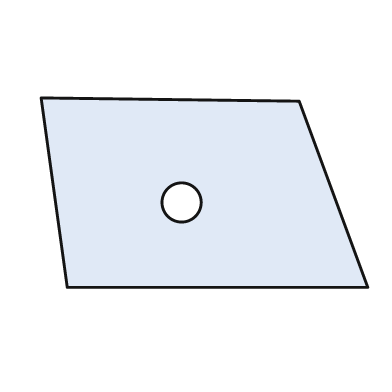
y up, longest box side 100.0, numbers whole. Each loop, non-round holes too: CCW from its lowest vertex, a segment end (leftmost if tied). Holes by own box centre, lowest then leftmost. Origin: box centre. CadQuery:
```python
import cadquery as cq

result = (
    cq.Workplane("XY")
    .moveTo(-42.0, -29.0)
    .lineTo(50.0, -29.0)
    .lineTo(29.0, 28.0)
    .lineTo(-50.0, 29.0)
    .close()
    .moveTo(-7.0, -3.0)
    .circle(6.0)
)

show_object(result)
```